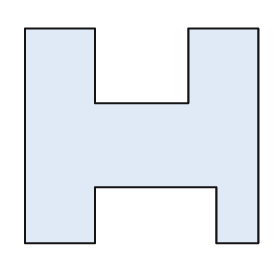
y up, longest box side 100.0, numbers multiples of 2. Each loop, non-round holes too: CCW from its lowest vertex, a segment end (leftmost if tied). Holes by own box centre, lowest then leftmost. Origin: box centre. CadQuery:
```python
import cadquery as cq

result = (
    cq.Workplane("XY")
    .moveTo(-50.0, -46.0)
    .lineTo(-20.0, -46.0)
    .lineTo(-20.0, -22.0)
    .lineTo(32.0, -22.0)
    .lineTo(32.0, -46.0)
    .lineTo(50.0, -46.0)
    .lineTo(50.0, 46.0)
    .lineTo(20.0, 46.0)
    .lineTo(20.0, 14.0)
    .lineTo(-20.0, 14.0)
    .lineTo(-20.0, 46.0)
    .lineTo(-50.0, 46.0)
    .close()
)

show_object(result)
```